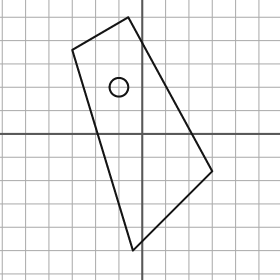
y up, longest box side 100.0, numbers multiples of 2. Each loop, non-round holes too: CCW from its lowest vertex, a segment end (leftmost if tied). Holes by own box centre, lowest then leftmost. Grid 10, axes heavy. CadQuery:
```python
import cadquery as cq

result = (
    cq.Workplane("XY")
    .moveTo(-4.0, -50.0)
    .lineTo(30.0, -16.0)
    .lineTo(-6.0, 50.0)
    .lineTo(-30.0, 36.0)
    .close()
    .moveTo(-10.0, 20.0)
    .circle(4.0)
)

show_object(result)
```